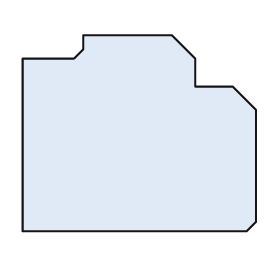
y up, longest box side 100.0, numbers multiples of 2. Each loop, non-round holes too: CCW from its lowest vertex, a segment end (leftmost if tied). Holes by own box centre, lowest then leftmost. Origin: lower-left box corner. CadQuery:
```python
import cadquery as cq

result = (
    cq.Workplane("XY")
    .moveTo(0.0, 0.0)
    .lineTo(96.0, 0.0)
    .lineTo(100.0, 4.0)
    .lineTo(100.0, 52.0)
    .lineTo(90.0, 62.0)
    .lineTo(74.0, 62.0)
    .lineTo(74.0, 74.0)
    .lineTo(64.0, 84.0)
    .lineTo(26.0, 84.0)
    .lineTo(26.0, 78.0)
    .lineTo(22.0, 74.0)
    .lineTo(0.0, 74.0)
    .close()
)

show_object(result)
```